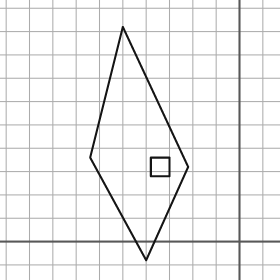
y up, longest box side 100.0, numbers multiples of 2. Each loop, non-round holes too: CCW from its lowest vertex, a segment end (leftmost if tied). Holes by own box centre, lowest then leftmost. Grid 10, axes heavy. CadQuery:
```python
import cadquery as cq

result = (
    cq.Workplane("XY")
    .moveTo(-40.0, -8.0)
    .lineTo(-22.0, 32.0)
    .lineTo(-50.0, 92.0)
    .lineTo(-64.0, 36.0)
    .close()
    .moveTo(-38.0, 28.0)
    .lineTo(-30.0, 28.0)
    .lineTo(-30.0, 36.0)
    .lineTo(-38.0, 36.0)
    .close()
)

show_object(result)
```